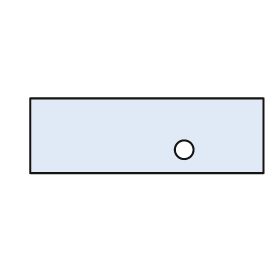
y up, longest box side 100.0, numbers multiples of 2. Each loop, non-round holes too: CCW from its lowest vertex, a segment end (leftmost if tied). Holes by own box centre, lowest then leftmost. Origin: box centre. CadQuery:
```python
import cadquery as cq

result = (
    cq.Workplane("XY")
    .moveTo(-50.0, -16.0)
    .lineTo(50.0, -16.0)
    .lineTo(50.0, 16.0)
    .lineTo(-50.0, 16.0)
    .close()
    .moveTo(16.0, -6.0)
    .circle(4.0)
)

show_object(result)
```